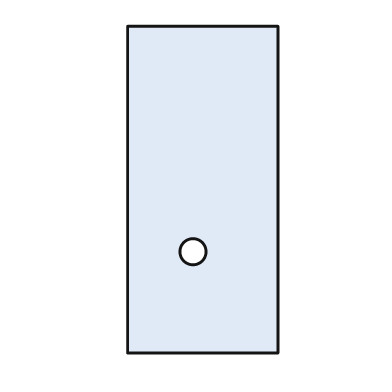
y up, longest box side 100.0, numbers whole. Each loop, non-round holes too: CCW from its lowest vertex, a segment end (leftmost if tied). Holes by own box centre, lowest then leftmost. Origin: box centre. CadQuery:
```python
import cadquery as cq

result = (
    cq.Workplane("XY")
    .moveTo(-23.0, -50.0)
    .lineTo(23.0, -50.0)
    .lineTo(23.0, 50.0)
    .lineTo(-23.0, 50.0)
    .close()
    .moveTo(-3.0, -19.0)
    .circle(4.0)
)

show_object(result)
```